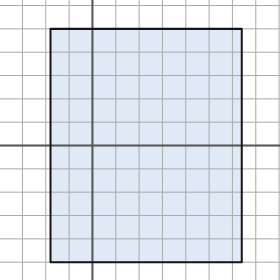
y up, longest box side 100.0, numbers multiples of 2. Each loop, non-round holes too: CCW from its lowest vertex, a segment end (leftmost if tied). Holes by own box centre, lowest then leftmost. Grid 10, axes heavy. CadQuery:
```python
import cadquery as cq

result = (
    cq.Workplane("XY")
    .moveTo(-18.0, -50.0)
    .lineTo(64.0, -50.0)
    .lineTo(64.0, 50.0)
    .lineTo(-18.0, 50.0)
    .close()
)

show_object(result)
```